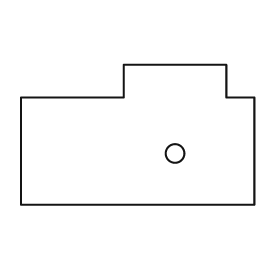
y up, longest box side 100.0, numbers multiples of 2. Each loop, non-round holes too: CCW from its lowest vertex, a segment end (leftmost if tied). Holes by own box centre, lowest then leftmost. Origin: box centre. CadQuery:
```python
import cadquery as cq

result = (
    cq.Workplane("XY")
    .moveTo(-50.0, -30.0)
    .lineTo(50.0, -30.0)
    .lineTo(50.0, 16.0)
    .lineTo(38.0, 16.0)
    .lineTo(38.0, 30.0)
    .lineTo(-6.0, 30.0)
    .lineTo(-6.0, 16.0)
    .lineTo(-50.0, 16.0)
    .close()
    .moveTo(16.0, -8.0)
    .circle(4.0)
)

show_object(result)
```